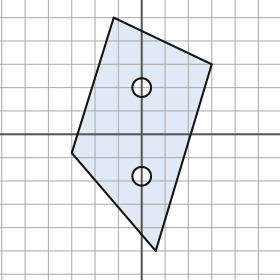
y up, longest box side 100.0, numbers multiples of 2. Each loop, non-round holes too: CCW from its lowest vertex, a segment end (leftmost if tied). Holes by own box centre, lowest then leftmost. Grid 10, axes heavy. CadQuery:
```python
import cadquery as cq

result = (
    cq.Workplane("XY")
    .moveTo(6.0, -50.0)
    .lineTo(30.0, 30.0)
    .lineTo(-12.0, 50.0)
    .lineTo(-30.0, -8.0)
    .close()
    .moveTo(0.0, -18.0)
    .circle(4.0)
    .moveTo(0.0, 20.0)
    .circle(4.0)
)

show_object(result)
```